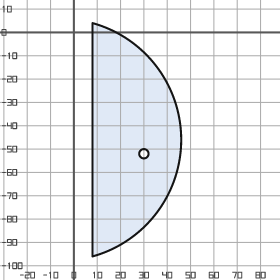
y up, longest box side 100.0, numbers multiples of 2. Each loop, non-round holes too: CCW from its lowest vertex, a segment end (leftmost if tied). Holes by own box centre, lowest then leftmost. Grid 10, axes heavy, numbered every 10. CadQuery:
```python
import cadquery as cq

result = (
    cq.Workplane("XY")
    .moveTo(8.0, -96.0)
    .threePointArc((46.0, -46.0), (8.0, 4.0))
    .close()
    .moveTo(30.0, -52.0)
    .circle(2.0)
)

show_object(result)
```